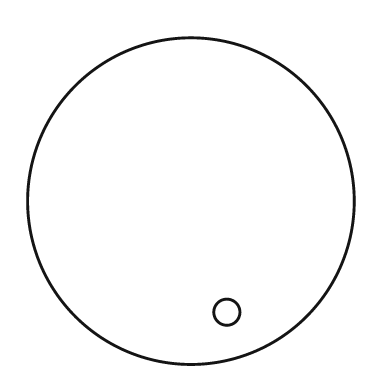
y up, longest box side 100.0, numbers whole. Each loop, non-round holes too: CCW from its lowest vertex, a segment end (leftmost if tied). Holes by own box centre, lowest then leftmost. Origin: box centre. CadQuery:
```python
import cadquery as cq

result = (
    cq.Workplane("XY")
    .moveTo(0.0, 0.0)
    .circle(50.0)
    .moveTo(11.0, -34.0)
    .circle(4.0)
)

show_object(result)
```